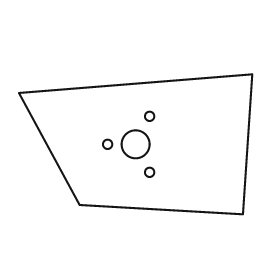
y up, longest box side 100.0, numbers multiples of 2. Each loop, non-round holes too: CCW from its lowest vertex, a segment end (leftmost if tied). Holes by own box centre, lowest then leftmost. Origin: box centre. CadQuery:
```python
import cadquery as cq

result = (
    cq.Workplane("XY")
    .moveTo(46.0, -30.0)
    .lineTo(50.0, 30.0)
    .lineTo(-50.0, 22.0)
    .lineTo(-24.0, -26.0)
    .close()
    .moveTo(6.0, -12.0)
    .circle(2.0)
    .moveTo(-12.0, 0.0)
    .circle(2.0)
    .moveTo(0.0, 0.0)
    .circle(6.0)
    .moveTo(6.0, 12.0)
    .circle(2.0)
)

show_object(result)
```